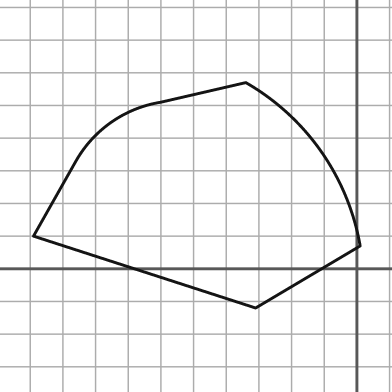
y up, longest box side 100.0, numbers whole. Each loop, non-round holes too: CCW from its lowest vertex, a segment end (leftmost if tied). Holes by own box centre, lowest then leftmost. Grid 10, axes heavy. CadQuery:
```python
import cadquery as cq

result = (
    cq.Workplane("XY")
    .moveTo(-31.0, -12.0)
    .lineTo(1.0, 7.0)
    .threePointArc((-11.0, 36.0), (-34.0, 57.0))
    .lineTo(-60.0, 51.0)
    .threePointArc((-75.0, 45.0), (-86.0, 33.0))
    .lineTo(-99.0, 10.0)
    .close()
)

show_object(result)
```